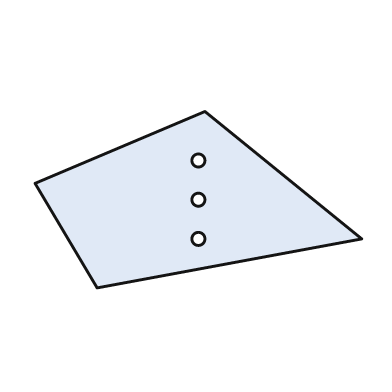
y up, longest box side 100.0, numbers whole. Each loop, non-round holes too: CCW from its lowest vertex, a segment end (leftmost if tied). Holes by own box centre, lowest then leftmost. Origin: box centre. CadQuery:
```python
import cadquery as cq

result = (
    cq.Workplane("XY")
    .moveTo(-31.0, -27.0)
    .lineTo(50.0, -12.0)
    .lineTo(2.0, 27.0)
    .lineTo(-50.0, 5.0)
    .close()
    .moveTo(0.0, -12.0)
    .circle(2.0)
    .moveTo(0.0, 0.0)
    .circle(2.0)
    .moveTo(0.0, 12.0)
    .circle(2.0)
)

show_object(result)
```